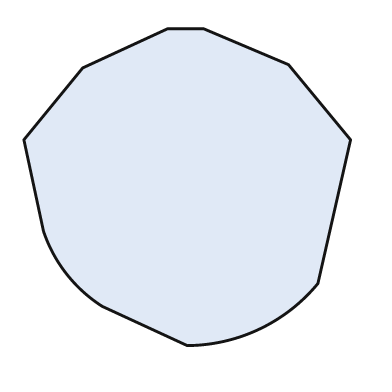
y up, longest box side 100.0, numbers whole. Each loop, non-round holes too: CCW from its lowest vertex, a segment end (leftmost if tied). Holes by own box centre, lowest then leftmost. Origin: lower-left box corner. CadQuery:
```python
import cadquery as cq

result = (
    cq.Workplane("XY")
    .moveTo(50.0, 0.0)
    .threePointArc((72.0, 5.0), (90.0, 19.0))
    .lineTo(100.0, 63.0)
    .lineTo(81.0, 86.0)
    .lineTo(55.0, 97.0)
    .lineTo(44.0, 97.0)
    .lineTo(18.0, 85.0)
    .lineTo(0.0, 63.0)
    .lineTo(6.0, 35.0)
    .threePointArc((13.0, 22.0), (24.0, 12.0))
    .close()
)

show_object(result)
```